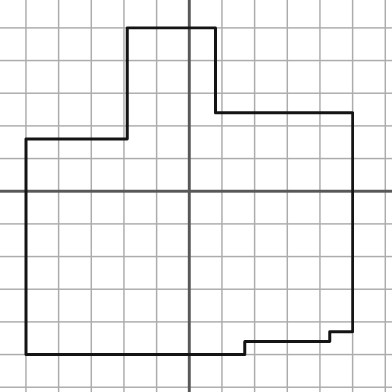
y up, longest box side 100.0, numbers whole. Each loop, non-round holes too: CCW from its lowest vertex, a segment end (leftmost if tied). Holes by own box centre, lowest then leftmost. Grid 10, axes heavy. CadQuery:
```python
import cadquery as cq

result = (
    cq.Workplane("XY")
    .moveTo(-50.0, -50.0)
    .lineTo(17.0, -50.0)
    .lineTo(17.0, -46.0)
    .lineTo(43.0, -46.0)
    .lineTo(43.0, -43.0)
    .lineTo(50.0, -43.0)
    .lineTo(50.0, 24.0)
    .lineTo(8.0, 24.0)
    .lineTo(8.0, 50.0)
    .lineTo(-19.0, 50.0)
    .lineTo(-19.0, 16.0)
    .lineTo(-50.0, 16.0)
    .close()
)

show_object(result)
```